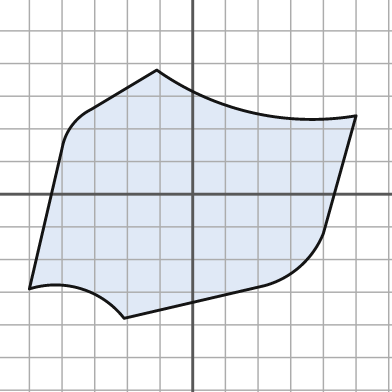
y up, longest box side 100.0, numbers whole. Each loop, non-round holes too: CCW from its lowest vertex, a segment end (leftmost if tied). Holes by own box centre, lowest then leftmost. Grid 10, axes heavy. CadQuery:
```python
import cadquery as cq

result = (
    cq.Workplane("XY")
    .moveTo(-21.0, -38.0)
    .lineTo(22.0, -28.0)
    .threePointArc((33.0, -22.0), (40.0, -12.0))
    .lineTo(50.0, 24.0)
    .threePointArc((18.0, 25.0), (-11.0, 38.0))
    .lineTo(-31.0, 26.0)
    .threePointArc((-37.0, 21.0), (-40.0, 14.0))
    .lineTo(-50.0, -29.0)
    .threePointArc((-34.0, -29.0), (-21.0, -38.0))
    .close()
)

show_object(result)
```